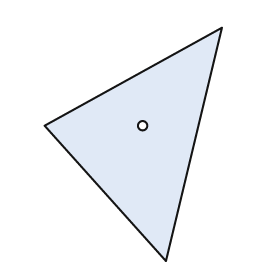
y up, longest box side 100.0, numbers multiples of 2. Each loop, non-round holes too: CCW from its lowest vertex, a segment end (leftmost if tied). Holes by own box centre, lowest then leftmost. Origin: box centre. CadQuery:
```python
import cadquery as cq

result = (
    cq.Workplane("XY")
    .moveTo(14.0, -50.0)
    .lineTo(38.0, 50.0)
    .lineTo(-38.0, 8.0)
    .close()
    .moveTo(4.0, 8.0)
    .circle(2.0)
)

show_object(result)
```